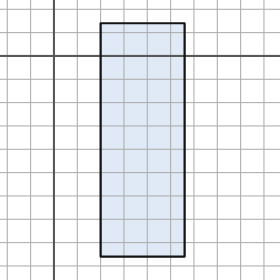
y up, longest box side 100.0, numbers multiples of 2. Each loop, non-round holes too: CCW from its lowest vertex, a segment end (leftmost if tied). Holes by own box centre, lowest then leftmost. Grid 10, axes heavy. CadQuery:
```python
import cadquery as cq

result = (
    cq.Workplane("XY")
    .moveTo(20.0, -86.0)
    .lineTo(56.0, -86.0)
    .lineTo(56.0, 14.0)
    .lineTo(20.0, 14.0)
    .close()
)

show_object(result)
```